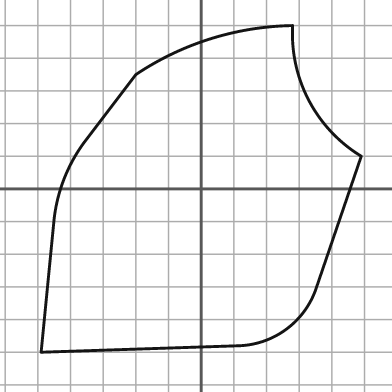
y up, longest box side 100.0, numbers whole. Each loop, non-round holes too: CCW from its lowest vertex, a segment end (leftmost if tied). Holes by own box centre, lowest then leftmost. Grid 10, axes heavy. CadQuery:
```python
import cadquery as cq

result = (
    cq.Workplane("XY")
    .moveTo(-49.0, -50.0)
    .lineTo(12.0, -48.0)
    .threePointArc((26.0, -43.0), (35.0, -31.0))
    .lineTo(49.0, 10.0)
    .threePointArc((33.0, 27.0), (28.0, 50.0))
    .threePointArc((3.0, 46.0), (-20.0, 35.0))
    .lineTo(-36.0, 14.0)
    .threePointArc((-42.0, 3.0), (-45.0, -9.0))
    .close()
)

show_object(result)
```